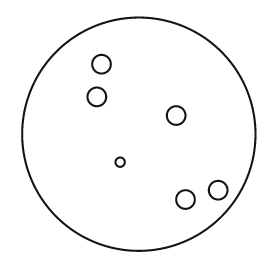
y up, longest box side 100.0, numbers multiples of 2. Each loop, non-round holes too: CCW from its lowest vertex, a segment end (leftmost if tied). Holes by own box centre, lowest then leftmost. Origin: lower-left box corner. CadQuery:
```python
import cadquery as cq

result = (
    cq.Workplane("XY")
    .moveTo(50.0, 50.0)
    .circle(50.0)
    .moveTo(70.0, 22.0)
    .circle(4.0)
    .moveTo(84.0, 26.0)
    .circle(4.0)
    .moveTo(42.0, 38.0)
    .circle(2.0)
    .moveTo(66.0, 58.0)
    .circle(4.0)
    .moveTo(32.0, 66.0)
    .circle(4.0)
    .moveTo(34.0, 80.0)
    .circle(4.0)
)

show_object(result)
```